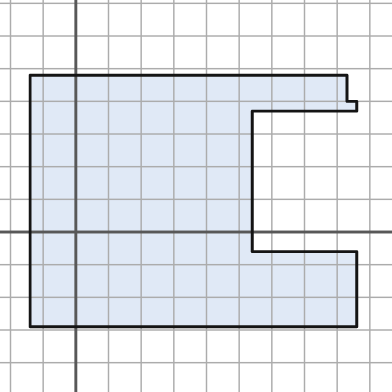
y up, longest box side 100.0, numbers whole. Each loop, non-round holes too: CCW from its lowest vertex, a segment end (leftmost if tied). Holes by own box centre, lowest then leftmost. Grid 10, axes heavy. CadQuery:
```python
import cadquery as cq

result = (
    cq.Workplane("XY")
    .moveTo(-14.0, -29.0)
    .lineTo(86.0, -29.0)
    .lineTo(86.0, -6.0)
    .lineTo(54.0, -6.0)
    .lineTo(54.0, 37.0)
    .lineTo(86.0, 37.0)
    .lineTo(86.0, 40.0)
    .lineTo(83.0, 40.0)
    .lineTo(83.0, 48.0)
    .lineTo(-14.0, 48.0)
    .close()
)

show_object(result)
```